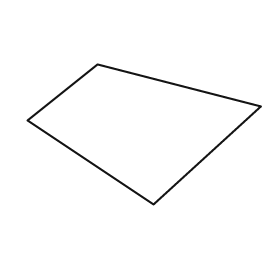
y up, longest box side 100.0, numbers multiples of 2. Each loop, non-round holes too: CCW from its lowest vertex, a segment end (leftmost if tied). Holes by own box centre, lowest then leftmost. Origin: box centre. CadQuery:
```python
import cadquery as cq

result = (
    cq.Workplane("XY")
    .moveTo(4.0, -30.0)
    .lineTo(50.0, 12.0)
    .lineTo(-20.0, 30.0)
    .lineTo(-50.0, 6.0)
    .close()
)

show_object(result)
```